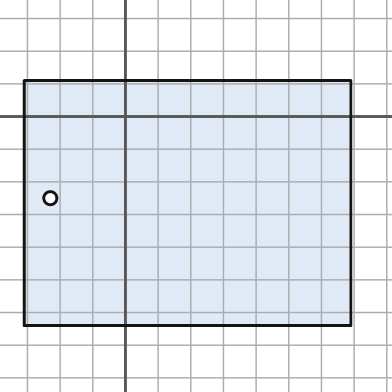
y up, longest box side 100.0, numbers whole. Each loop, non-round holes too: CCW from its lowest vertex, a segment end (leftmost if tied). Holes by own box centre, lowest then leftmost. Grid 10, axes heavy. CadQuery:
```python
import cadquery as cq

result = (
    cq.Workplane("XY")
    .moveTo(-31.0, -64.0)
    .lineTo(69.0, -64.0)
    .lineTo(69.0, 11.0)
    .lineTo(-31.0, 11.0)
    .close()
    .moveTo(-23.0, -25.0)
    .circle(2.0)
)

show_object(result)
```